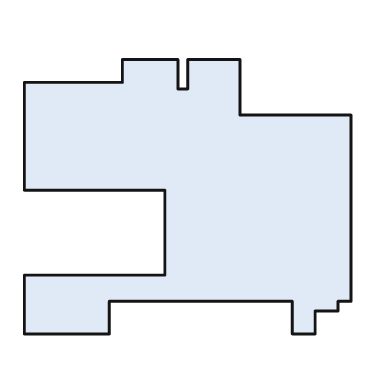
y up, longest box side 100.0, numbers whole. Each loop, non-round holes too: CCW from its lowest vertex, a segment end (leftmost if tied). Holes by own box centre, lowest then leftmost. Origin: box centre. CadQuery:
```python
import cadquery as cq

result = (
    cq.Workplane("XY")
    .moveTo(-50.0, -42.0)
    .lineTo(-24.0, -42.0)
    .lineTo(-24.0, -32.0)
    .lineTo(32.0, -32.0)
    .lineTo(32.0, -42.0)
    .lineTo(39.0, -42.0)
    .lineTo(39.0, -35.0)
    .lineTo(46.0, -35.0)
    .lineTo(46.0, -32.0)
    .lineTo(50.0, -32.0)
    .lineTo(50.0, 25.0)
    .lineTo(16.0, 25.0)
    .lineTo(16.0, 42.0)
    .lineTo(0.0, 42.0)
    .lineTo(0.0, 33.0)
    .lineTo(-3.0, 33.0)
    .lineTo(-3.0, 42.0)
    .lineTo(-20.0, 42.0)
    .lineTo(-20.0, 35.0)
    .lineTo(-50.0, 35.0)
    .lineTo(-50.0, 2.0)
    .lineTo(-7.0, 2.0)
    .lineTo(-7.0, -24.0)
    .lineTo(-50.0, -24.0)
    .close()
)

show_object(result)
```